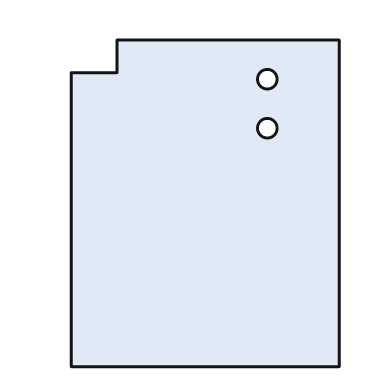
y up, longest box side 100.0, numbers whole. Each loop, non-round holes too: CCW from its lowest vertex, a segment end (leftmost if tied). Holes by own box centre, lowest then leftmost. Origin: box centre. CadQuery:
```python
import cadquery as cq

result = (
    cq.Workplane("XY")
    .moveTo(-41.0, -50.0)
    .lineTo(41.0, -50.0)
    .lineTo(41.0, 50.0)
    .lineTo(-27.0, 50.0)
    .lineTo(-27.0, 40.0)
    .lineTo(-41.0, 40.0)
    .close()
    .moveTo(19.0, 23.0)
    .circle(3.0)
    .moveTo(19.0, 38.0)
    .circle(3.0)
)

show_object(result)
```